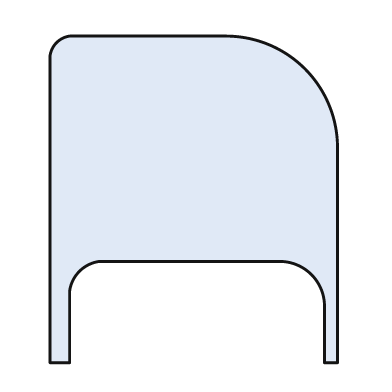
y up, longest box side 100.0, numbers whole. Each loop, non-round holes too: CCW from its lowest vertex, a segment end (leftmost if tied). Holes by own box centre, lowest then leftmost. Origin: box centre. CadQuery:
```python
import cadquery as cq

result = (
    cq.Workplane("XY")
    .moveTo(-44.0, -50.0)
    .lineTo(-38.0, -50.0)
    .lineTo(-38.0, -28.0)
    .threePointArc((-35.0, -22.0), (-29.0, -19.0))
    .lineTo(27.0, -19.0)
    .threePointArc((36.0, -23.0), (40.0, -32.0))
    .lineTo(40.0, -50.0)
    .lineTo(44.0, -50.0)
    .lineTo(44.0, 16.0)
    .threePointArc((34.0, 40.0), (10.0, 50.0))
    .lineTo(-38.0, 50.0)
    .threePointArc((-42.0, 48.0), (-44.0, 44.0))
    .close()
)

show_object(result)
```